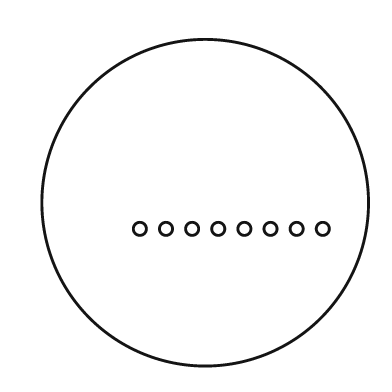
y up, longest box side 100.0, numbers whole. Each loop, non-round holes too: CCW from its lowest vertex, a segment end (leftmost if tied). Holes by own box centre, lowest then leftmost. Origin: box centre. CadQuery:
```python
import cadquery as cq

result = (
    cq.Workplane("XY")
    .moveTo(0.0, 0.0)
    .circle(50.0)
    .moveTo(-20.0, -8.0)
    .circle(2.0)
    .moveTo(-12.0, -8.0)
    .circle(2.0)
    .moveTo(-4.0, -8.0)
    .circle(2.0)
    .moveTo(4.0, -8.0)
    .circle(2.0)
    .moveTo(12.0, -8.0)
    .circle(2.0)
    .moveTo(20.0, -8.0)
    .circle(2.0)
    .moveTo(28.0, -8.0)
    .circle(2.0)
    .moveTo(36.0, -8.0)
    .circle(2.0)
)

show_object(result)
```